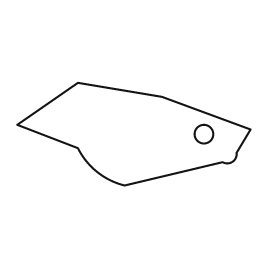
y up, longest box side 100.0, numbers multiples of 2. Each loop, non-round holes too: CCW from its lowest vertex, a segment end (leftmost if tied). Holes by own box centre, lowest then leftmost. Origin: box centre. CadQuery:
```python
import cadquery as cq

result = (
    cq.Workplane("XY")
    .moveTo(-4.0, -22.0)
    .lineTo(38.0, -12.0)
    .threePointArc((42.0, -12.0), (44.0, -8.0))
    .lineTo(50.0, 2.0)
    .lineTo(12.0, 16.0)
    .lineTo(-24.0, 22.0)
    .lineTo(-50.0, 4.0)
    .lineTo(-24.0, -6.0)
    .threePointArc((-16.0, -16.0), (-4.0, -22.0))
    .close()
    .moveTo(30.0, 0.0)
    .circle(4.0)
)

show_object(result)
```